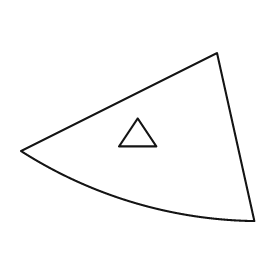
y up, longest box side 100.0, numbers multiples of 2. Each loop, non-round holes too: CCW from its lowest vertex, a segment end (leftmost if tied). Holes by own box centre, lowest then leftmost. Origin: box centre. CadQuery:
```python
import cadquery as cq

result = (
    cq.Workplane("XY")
    .moveTo(50.0, -36.0)
    .lineTo(34.0, 36.0)
    .lineTo(-50.0, -6.0)
    .threePointArc((-2.0, -28.0), (50.0, -36.0))
    .close()
    .moveTo(-8.0, -4.0)
    .lineTo(8.0, -4.0)
    .lineTo(0.0, 8.0)
    .close()
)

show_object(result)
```